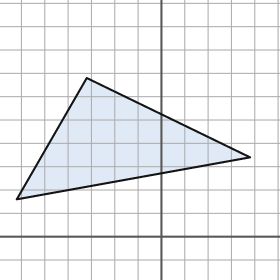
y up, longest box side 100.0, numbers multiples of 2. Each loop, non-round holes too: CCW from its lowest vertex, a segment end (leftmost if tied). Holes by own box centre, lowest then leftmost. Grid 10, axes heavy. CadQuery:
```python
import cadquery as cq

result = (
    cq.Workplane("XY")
    .moveTo(-62.0, 16.0)
    .lineTo(38.0, 34.0)
    .lineTo(-32.0, 68.0)
    .close()
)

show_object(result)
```